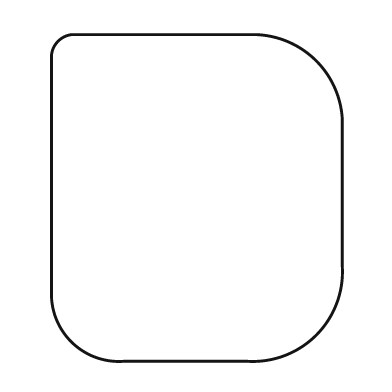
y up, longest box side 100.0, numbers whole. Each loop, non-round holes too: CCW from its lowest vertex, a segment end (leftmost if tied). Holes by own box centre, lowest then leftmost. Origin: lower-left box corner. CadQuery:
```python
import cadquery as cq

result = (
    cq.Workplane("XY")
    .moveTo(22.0, 0.0)
    .lineTo(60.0, 0.0)
    .threePointArc((81.0, 8.0), (89.0, 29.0))
    .lineTo(89.0, 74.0)
    .threePointArc((81.0, 92.0), (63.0, 100.0))
    .lineTo(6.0, 100.0)
    .threePointArc((2.0, 98.0), (0.0, 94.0))
    .lineTo(0.0, 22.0)
    .threePointArc((6.0, 6.0), (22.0, 0.0))
    .close()
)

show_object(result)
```